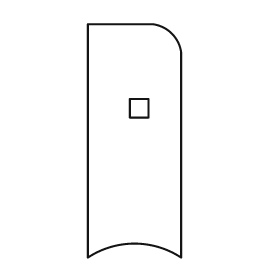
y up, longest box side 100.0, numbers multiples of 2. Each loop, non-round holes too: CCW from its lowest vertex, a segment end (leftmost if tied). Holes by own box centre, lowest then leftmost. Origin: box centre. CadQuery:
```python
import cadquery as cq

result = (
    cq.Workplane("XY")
    .moveTo(-20.0, -50.0)
    .threePointArc((0.0, -44.0), (20.0, -50.0))
    .lineTo(20.0, 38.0)
    .threePointArc((16.0, 46.0), (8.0, 50.0))
    .lineTo(-20.0, 50.0)
    .close()
    .moveTo(-2.0, 10.0)
    .lineTo(6.0, 10.0)
    .lineTo(6.0, 18.0)
    .lineTo(-2.0, 18.0)
    .close()
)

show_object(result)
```